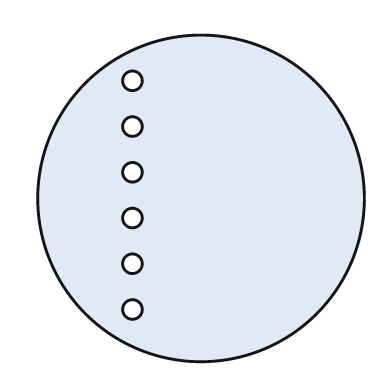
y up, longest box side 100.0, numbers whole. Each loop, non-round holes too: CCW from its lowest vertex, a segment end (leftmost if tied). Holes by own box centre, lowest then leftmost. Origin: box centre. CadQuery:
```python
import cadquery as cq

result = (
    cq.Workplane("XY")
    .moveTo(0.0, 0.0)
    .circle(50.0)
    .moveTo(-21.0, -34.0)
    .circle(3.0)
    .moveTo(-21.0, -20.0)
    .circle(3.0)
    .moveTo(-21.0, -6.0)
    .circle(3.0)
    .moveTo(-21.0, 8.0)
    .circle(3.0)
    .moveTo(-21.0, 22.0)
    .circle(3.0)
    .moveTo(-21.0, 36.0)
    .circle(3.0)
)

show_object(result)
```